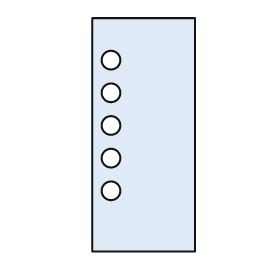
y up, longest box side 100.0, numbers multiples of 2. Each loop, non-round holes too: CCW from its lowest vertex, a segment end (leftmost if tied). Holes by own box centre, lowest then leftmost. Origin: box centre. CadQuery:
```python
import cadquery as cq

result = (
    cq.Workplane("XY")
    .moveTo(-22.0, -50.0)
    .lineTo(22.0, -50.0)
    .lineTo(22.0, 50.0)
    .lineTo(-22.0, 50.0)
    .close()
    .moveTo(-14.0, -24.0)
    .circle(4.0)
    .moveTo(-14.0, -10.0)
    .circle(4.0)
    .moveTo(-14.0, 4.0)
    .circle(4.0)
    .moveTo(-14.0, 18.0)
    .circle(4.0)
    .moveTo(-14.0, 32.0)
    .circle(4.0)
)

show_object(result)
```